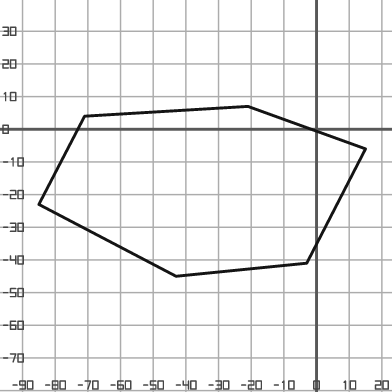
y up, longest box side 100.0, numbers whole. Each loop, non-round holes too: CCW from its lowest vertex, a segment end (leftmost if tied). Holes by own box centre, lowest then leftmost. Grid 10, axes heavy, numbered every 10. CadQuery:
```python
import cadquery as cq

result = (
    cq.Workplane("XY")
    .moveTo(-43.0, -45.0)
    .lineTo(-3.0, -41.0)
    .lineTo(15.0, -6.0)
    .lineTo(-21.0, 7.0)
    .lineTo(-71.0, 4.0)
    .lineTo(-85.0, -23.0)
    .close()
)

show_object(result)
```